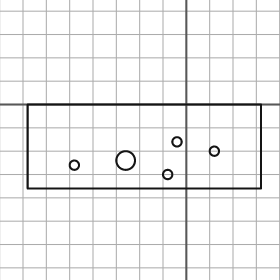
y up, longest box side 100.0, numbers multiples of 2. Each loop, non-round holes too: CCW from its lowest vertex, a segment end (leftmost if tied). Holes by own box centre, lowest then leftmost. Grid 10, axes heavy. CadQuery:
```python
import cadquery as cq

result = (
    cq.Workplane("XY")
    .moveTo(-68.0, -36.0)
    .lineTo(32.0, -36.0)
    .lineTo(32.0, 0.0)
    .lineTo(-68.0, 0.0)
    .close()
    .moveTo(-8.0, -30.0)
    .circle(2.0)
    .moveTo(-48.0, -26.0)
    .circle(2.0)
    .moveTo(-26.0, -24.0)
    .circle(4.0)
    .moveTo(12.0, -20.0)
    .circle(2.0)
    .moveTo(-4.0, -16.0)
    .circle(2.0)
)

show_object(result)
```